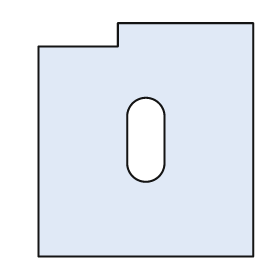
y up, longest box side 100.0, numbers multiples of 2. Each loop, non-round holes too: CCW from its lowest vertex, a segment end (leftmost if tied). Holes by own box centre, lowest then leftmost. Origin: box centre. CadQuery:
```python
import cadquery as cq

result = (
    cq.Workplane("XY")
    .moveTo(-46.0, -50.0)
    .lineTo(46.0, -50.0)
    .lineTo(46.0, 50.0)
    .lineTo(-12.0, 50.0)
    .lineTo(-12.0, 40.0)
    .lineTo(-46.0, 40.0)
    .close()
    .moveTo(-8.0, -10.0)
    .threePointArc((0.0, -18.0), (8.0, -10.0))
    .lineTo(8.0, 10.0)
    .threePointArc((0.0, 18.0), (-8.0, 10.0))
    .close()
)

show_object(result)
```